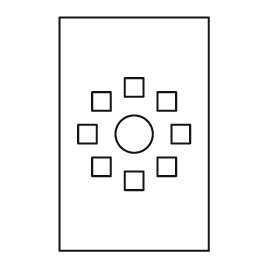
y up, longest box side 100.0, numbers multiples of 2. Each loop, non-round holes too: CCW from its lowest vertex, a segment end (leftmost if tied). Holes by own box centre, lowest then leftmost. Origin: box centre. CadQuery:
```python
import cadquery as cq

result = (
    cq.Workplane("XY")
    .moveTo(-32.0, -50.0)
    .lineTo(32.0, -50.0)
    .lineTo(32.0, 50.0)
    .lineTo(-32.0, 50.0)
    .close()
    .moveTo(-4.0, -24.0)
    .lineTo(4.0, -24.0)
    .lineTo(4.0, -16.0)
    .lineTo(-4.0, -16.0)
    .close()
    .moveTo(-18.0, -18.0)
    .lineTo(-10.0, -18.0)
    .lineTo(-10.0, -10.0)
    .lineTo(-18.0, -10.0)
    .close()
    .moveTo(10.0, -18.0)
    .lineTo(18.0, -18.0)
    .lineTo(18.0, -10.0)
    .lineTo(10.0, -10.0)
    .close()
    .moveTo(-24.0, -4.0)
    .lineTo(-16.0, -4.0)
    .lineTo(-16.0, 4.0)
    .lineTo(-24.0, 4.0)
    .close()
    .moveTo(0.0, 0.0)
    .circle(8.0)
    .moveTo(16.0, -4.0)
    .lineTo(24.0, -4.0)
    .lineTo(24.0, 4.0)
    .lineTo(16.0, 4.0)
    .close()
    .moveTo(-18.0, 10.0)
    .lineTo(-10.0, 10.0)
    .lineTo(-10.0, 18.0)
    .lineTo(-18.0, 18.0)
    .close()
    .moveTo(10.0, 10.0)
    .lineTo(18.0, 10.0)
    .lineTo(18.0, 18.0)
    .lineTo(10.0, 18.0)
    .close()
    .moveTo(-4.0, 16.0)
    .lineTo(4.0, 16.0)
    .lineTo(4.0, 24.0)
    .lineTo(-4.0, 24.0)
    .close()
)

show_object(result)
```